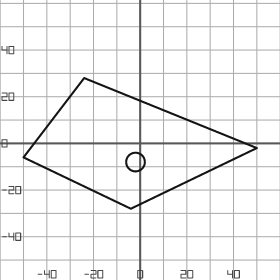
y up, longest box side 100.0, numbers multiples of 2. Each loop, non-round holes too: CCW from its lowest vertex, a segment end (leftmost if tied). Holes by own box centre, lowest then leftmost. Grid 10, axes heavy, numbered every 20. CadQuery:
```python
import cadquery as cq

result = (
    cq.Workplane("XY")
    .moveTo(-4.0, -28.0)
    .lineTo(50.0, -2.0)
    .lineTo(-24.0, 28.0)
    .lineTo(-50.0, -6.0)
    .close()
    .moveTo(-2.0, -8.0)
    .circle(4.0)
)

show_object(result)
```